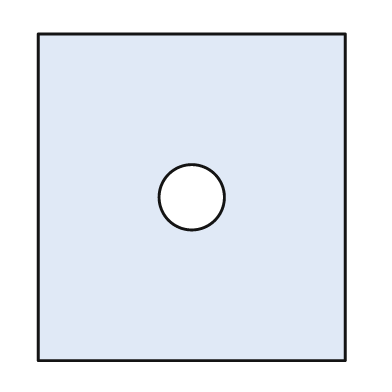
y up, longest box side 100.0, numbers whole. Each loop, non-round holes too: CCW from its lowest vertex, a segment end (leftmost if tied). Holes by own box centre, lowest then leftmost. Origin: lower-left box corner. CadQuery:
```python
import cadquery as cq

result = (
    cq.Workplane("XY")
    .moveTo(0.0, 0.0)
    .lineTo(94.0, 0.0)
    .lineTo(94.0, 100.0)
    .lineTo(0.0, 100.0)
    .close()
    .moveTo(47.0, 50.0)
    .circle(10.0)
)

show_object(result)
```